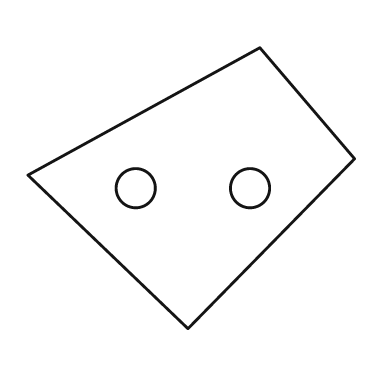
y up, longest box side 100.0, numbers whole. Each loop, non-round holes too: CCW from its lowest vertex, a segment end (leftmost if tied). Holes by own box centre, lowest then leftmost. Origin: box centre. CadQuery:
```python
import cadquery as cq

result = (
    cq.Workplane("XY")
    .moveTo(-1.0, -43.0)
    .lineTo(50.0, 9.0)
    .lineTo(21.0, 43.0)
    .lineTo(-50.0, 4.0)
    .close()
    .moveTo(-17.0, 0.0)
    .circle(6.0)
    .moveTo(18.0, 0.0)
    .circle(6.0)
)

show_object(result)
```